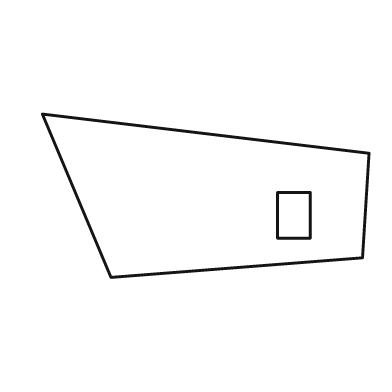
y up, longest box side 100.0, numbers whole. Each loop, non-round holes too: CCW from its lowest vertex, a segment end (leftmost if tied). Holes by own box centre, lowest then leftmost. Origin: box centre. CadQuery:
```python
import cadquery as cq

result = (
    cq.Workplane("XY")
    .moveTo(-29.0, -25.0)
    .lineTo(48.0, -19.0)
    .lineTo(50.0, 13.0)
    .lineTo(-50.0, 25.0)
    .close()
    .moveTo(22.0, -13.0)
    .lineTo(32.0, -13.0)
    .lineTo(32.0, 1.0)
    .lineTo(22.0, 1.0)
    .close()
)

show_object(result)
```